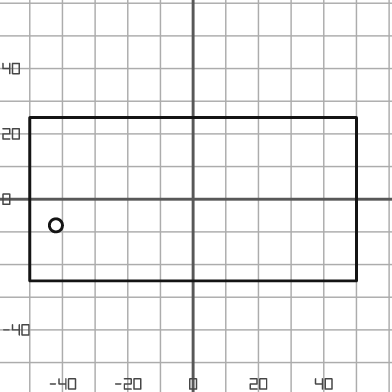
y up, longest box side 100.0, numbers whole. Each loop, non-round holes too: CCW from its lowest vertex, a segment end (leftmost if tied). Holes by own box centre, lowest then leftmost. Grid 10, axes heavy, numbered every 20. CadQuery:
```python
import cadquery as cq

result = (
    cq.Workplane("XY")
    .moveTo(-50.0, -25.0)
    .lineTo(50.0, -25.0)
    .lineTo(50.0, 25.0)
    .lineTo(-50.0, 25.0)
    .close()
    .moveTo(-42.0, -8.0)
    .circle(2.0)
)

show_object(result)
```